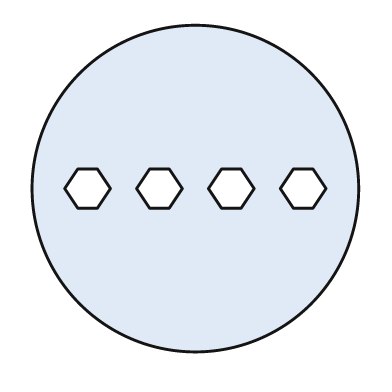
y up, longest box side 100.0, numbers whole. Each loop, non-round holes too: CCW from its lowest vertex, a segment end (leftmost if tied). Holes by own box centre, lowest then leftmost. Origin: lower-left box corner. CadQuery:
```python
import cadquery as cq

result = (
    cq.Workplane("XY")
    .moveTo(50.0, 50.0)
    .circle(50.0)
    .moveTo(14.0, 44.0)
    .lineTo(20.0, 44.0)
    .lineTo(24.0, 50.0)
    .lineTo(20.0, 56.0)
    .lineTo(14.0, 56.0)
    .lineTo(10.0, 50.0)
    .close()
    .moveTo(36.0, 44.0)
    .lineTo(42.0, 44.0)
    .lineTo(46.0, 50.0)
    .lineTo(42.0, 56.0)
    .lineTo(36.0, 56.0)
    .lineTo(32.0, 50.0)
    .close()
    .moveTo(58.0, 44.0)
    .lineTo(64.0, 44.0)
    .lineTo(68.0, 50.0)
    .lineTo(64.0, 56.0)
    .lineTo(58.0, 56.0)
    .lineTo(54.0, 50.0)
    .close()
    .moveTo(80.0, 44.0)
    .lineTo(86.0, 44.0)
    .lineTo(90.0, 50.0)
    .lineTo(86.0, 56.0)
    .lineTo(80.0, 56.0)
    .lineTo(76.0, 50.0)
    .close()
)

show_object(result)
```